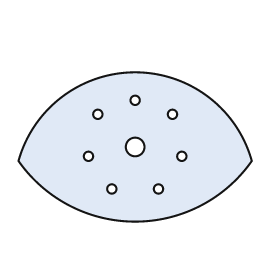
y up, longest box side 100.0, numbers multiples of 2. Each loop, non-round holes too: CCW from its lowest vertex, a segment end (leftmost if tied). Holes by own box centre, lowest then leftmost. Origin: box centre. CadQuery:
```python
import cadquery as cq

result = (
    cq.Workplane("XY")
    .moveTo(-50.0, -6.0)
    .threePointArc((0.0, -32.0), (50.0, -6.0))
    .threePointArc((0.0, 32.0), (-50.0, -6.0))
    .close()
    .moveTo(-10.0, -18.0)
    .circle(2.0)
    .moveTo(10.0, -18.0)
    .circle(2.0)
    .moveTo(-20.0, -4.0)
    .circle(2.0)
    .moveTo(20.0, -4.0)
    .circle(2.0)
    .moveTo(0.0, 0.0)
    .circle(4.0)
    .moveTo(-16.0, 14.0)
    .circle(2.0)
    .moveTo(16.0, 14.0)
    .circle(2.0)
    .moveTo(0.0, 20.0)
    .circle(2.0)
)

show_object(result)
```